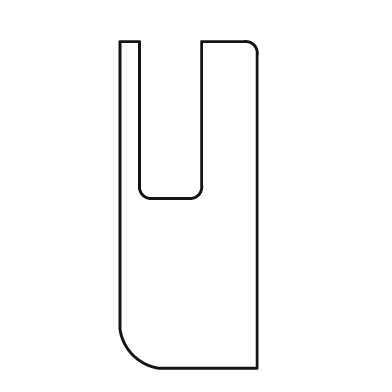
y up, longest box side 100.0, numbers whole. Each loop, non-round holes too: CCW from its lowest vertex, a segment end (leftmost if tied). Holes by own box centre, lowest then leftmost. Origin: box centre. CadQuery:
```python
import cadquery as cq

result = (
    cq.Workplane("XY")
    .moveTo(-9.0, -50.0)
    .lineTo(21.0, -50.0)
    .lineTo(21.0, 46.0)
    .threePointArc((20.0, 49.0), (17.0, 50.0))
    .lineTo(4.0, 50.0)
    .lineTo(4.0, 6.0)
    .threePointArc((3.0, 3.0), (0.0, 2.0))
    .lineTo(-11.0, 2.0)
    .threePointArc((-14.0, 3.0), (-15.0, 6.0))
    .lineTo(-15.0, 50.0)
    .lineTo(-21.0, 50.0)
    .lineTo(-21.0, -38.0)
    .threePointArc((-17.0, -46.0), (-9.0, -50.0))
    .close()
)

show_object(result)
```